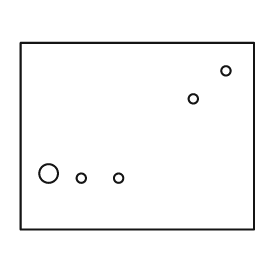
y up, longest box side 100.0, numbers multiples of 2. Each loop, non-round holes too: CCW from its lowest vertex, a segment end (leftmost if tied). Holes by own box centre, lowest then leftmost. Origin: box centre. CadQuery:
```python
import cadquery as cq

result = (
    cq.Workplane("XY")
    .moveTo(-50.0, -40.0)
    .lineTo(50.0, -40.0)
    .lineTo(50.0, 40.0)
    .lineTo(-50.0, 40.0)
    .close()
    .moveTo(-24.0, -18.0)
    .circle(2.0)
    .moveTo(-8.0, -18.0)
    .circle(2.0)
    .moveTo(-38.0, -16.0)
    .circle(4.0)
    .moveTo(24.0, 16.0)
    .circle(2.0)
    .moveTo(38.0, 28.0)
    .circle(2.0)
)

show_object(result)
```